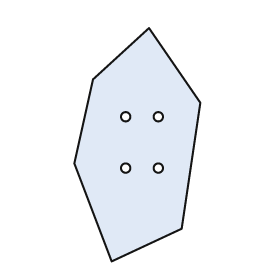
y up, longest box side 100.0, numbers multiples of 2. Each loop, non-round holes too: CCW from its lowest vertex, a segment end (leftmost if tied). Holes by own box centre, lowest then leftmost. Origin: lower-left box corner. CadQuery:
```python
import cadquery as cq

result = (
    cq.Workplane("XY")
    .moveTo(16.0, 0.0)
    .lineTo(46.0, 14.0)
    .lineTo(54.0, 68.0)
    .lineTo(32.0, 100.0)
    .lineTo(8.0, 78.0)
    .lineTo(0.0, 42.0)
    .close()
    .moveTo(22.0, 40.0)
    .circle(2.0)
    .moveTo(36.0, 40.0)
    .circle(2.0)
    .moveTo(22.0, 62.0)
    .circle(2.0)
    .moveTo(36.0, 62.0)
    .circle(2.0)
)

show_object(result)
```